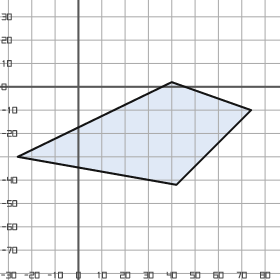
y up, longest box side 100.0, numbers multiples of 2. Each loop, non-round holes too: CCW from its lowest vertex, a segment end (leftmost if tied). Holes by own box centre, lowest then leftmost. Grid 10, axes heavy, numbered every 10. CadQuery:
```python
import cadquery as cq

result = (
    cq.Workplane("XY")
    .moveTo(42.0, -42.0)
    .lineTo(74.0, -10.0)
    .lineTo(40.0, 2.0)
    .lineTo(-26.0, -30.0)
    .close()
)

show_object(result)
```